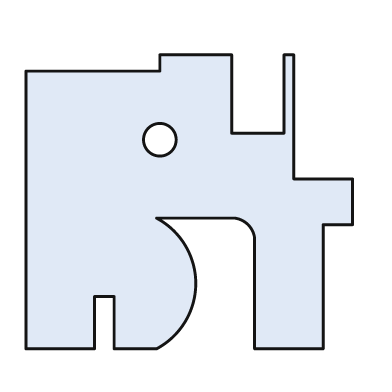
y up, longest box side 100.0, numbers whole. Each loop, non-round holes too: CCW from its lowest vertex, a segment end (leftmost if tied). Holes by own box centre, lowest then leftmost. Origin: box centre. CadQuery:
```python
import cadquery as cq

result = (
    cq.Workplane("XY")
    .moveTo(-50.0, -45.0)
    .lineTo(-29.0, -45.0)
    .lineTo(-29.0, -29.0)
    .lineTo(-23.0, -29.0)
    .lineTo(-23.0, -45.0)
    .lineTo(-10.0, -45.0)
    .threePointArc((2.0, -25.0), (-10.0, -5.0))
    .lineTo(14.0, -5.0)
    .threePointArc((18.0, -7.0), (20.0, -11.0))
    .lineTo(20.0, -45.0)
    .lineTo(41.0, -45.0)
    .lineTo(41.0, -7.0)
    .lineTo(50.0, -7.0)
    .lineTo(50.0, 7.0)
    .lineTo(32.0, 7.0)
    .lineTo(32.0, 45.0)
    .lineTo(29.0, 45.0)
    .lineTo(29.0, 21.0)
    .lineTo(13.0, 21.0)
    .lineTo(13.0, 45.0)
    .lineTo(-9.0, 45.0)
    .lineTo(-9.0, 40.0)
    .lineTo(-50.0, 40.0)
    .close()
    .moveTo(-9.0, 19.0)
    .circle(5.0)
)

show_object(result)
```